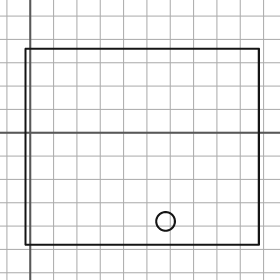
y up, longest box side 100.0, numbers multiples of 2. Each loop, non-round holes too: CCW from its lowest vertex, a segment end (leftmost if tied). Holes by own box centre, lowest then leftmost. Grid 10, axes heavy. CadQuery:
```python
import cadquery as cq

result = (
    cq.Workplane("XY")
    .moveTo(-2.0, -48.0)
    .lineTo(98.0, -48.0)
    .lineTo(98.0, 36.0)
    .lineTo(-2.0, 36.0)
    .close()
    .moveTo(58.0, -38.0)
    .circle(4.0)
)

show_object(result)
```